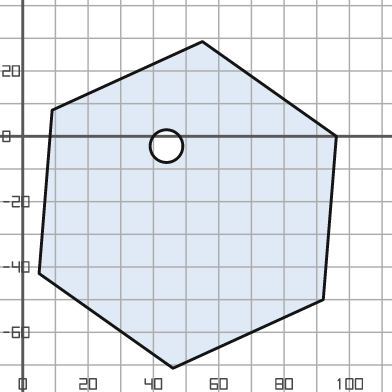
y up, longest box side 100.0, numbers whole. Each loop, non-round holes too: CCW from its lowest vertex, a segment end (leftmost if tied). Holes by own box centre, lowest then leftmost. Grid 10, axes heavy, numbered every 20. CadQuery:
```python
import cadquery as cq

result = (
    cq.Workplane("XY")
    .moveTo(46.0, -71.0)
    .lineTo(92.0, -50.0)
    .lineTo(96.0, 0.0)
    .lineTo(55.0, 29.0)
    .lineTo(9.0, 8.0)
    .lineTo(5.0, -42.0)
    .close()
    .moveTo(44.0, -3.0)
    .circle(5.0)
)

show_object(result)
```